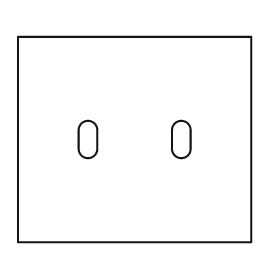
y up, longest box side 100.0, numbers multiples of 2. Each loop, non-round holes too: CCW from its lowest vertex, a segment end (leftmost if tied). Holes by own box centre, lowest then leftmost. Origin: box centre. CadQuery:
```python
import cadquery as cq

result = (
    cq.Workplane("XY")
    .moveTo(-50.0, -44.0)
    .lineTo(50.0, -44.0)
    .lineTo(50.0, 44.0)
    .lineTo(-50.0, 44.0)
    .close()
    .moveTo(-24.0, -4.0)
    .threePointArc((-20.0, -8.0), (-16.0, -4.0))
    .lineTo(-16.0, 4.0)
    .threePointArc((-20.0, 8.0), (-24.0, 4.0))
    .close()
    .moveTo(16.0, -4.0)
    .threePointArc((20.0, -8.0), (24.0, -4.0))
    .lineTo(24.0, 4.0)
    .threePointArc((20.0, 8.0), (16.0, 4.0))
    .close()
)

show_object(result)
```